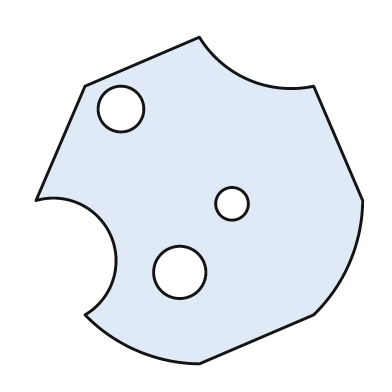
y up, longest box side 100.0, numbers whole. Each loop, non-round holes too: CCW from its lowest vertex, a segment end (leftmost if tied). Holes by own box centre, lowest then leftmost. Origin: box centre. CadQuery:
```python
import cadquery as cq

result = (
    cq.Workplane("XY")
    .moveTo(0.0, -50.0)
    .lineTo(35.0, -35.0)
    .threePointArc((46.0, -19.0), (50.0, 0.0))
    .lineTo(35.0, 35.0)
    .threePointArc((15.0, 37.0), (0.0, 50.0))
    .lineTo(-35.0, 35.0)
    .lineTo(-50.0, 0.0)
    .threePointArc((-27.0, -11.0), (-35.0, -35.0))
    .threePointArc((-19.0, -46.0), (0.0, -50.0))
    .close()
    .moveTo(-6.0, -22.0)
    .circle(8.0)
    .moveTo(10.0, -1.0)
    .circle(5.0)
    .moveTo(-24.0, 28.0)
    .circle(7.0)
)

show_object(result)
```